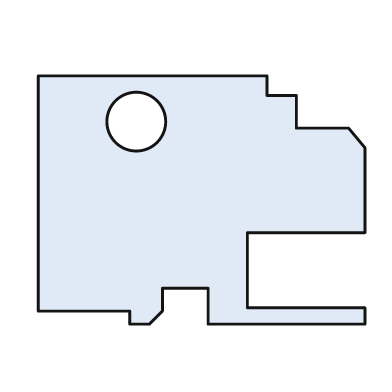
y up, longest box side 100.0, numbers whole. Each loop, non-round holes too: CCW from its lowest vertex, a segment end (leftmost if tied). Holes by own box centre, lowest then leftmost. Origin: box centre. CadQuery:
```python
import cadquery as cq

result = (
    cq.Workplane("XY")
    .moveTo(-22.0, -38.0)
    .lineTo(-16.0, -38.0)
    .lineTo(-12.0, -34.0)
    .lineTo(-12.0, -27.0)
    .lineTo(2.0, -27.0)
    .lineTo(2.0, -38.0)
    .lineTo(50.0, -38.0)
    .lineTo(50.0, -33.0)
    .lineTo(14.0, -33.0)
    .lineTo(14.0, -10.0)
    .lineTo(50.0, -10.0)
    .lineTo(50.0, 16.0)
    .lineTo(45.0, 22.0)
    .lineTo(29.0, 22.0)
    .lineTo(29.0, 32.0)
    .lineTo(20.0, 32.0)
    .lineTo(20.0, 38.0)
    .lineTo(-50.0, 38.0)
    .lineTo(-50.0, -34.0)
    .lineTo(-22.0, -34.0)
    .close()
    .moveTo(-20.0, 24.0)
    .circle(9.0)
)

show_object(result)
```